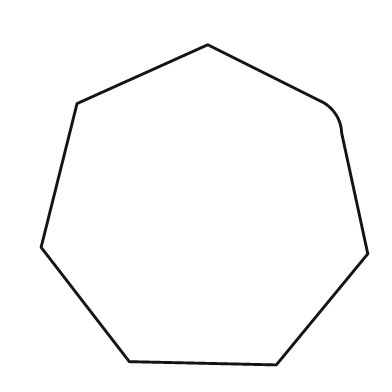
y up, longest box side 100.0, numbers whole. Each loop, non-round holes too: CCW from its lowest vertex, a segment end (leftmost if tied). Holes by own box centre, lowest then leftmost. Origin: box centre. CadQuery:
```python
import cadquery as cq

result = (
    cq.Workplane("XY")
    .moveTo(22.0, -49.0)
    .lineTo(50.0, -15.0)
    .lineTo(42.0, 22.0)
    .threePointArc((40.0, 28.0), (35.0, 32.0))
    .lineTo(1.0, 49.0)
    .lineTo(-39.0, 31.0)
    .lineTo(-50.0, -13.0)
    .lineTo(-23.0, -48.0)
    .close()
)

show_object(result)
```